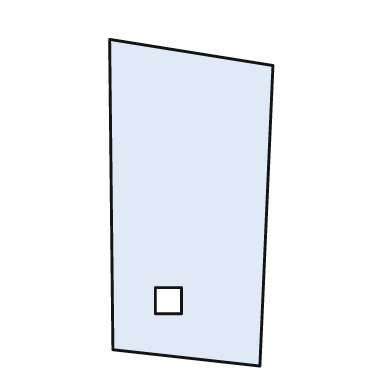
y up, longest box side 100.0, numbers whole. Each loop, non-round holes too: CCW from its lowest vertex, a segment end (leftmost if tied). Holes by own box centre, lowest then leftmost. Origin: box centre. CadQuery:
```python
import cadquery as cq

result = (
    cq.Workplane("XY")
    .moveTo(21.0, -50.0)
    .lineTo(25.0, 42.0)
    .lineTo(-25.0, 50.0)
    .lineTo(-24.0, -45.0)
    .close()
    .moveTo(-11.0, -34.0)
    .lineTo(-3.0, -34.0)
    .lineTo(-3.0, -26.0)
    .lineTo(-11.0, -26.0)
    .close()
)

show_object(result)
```